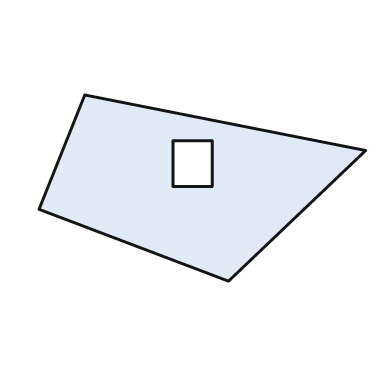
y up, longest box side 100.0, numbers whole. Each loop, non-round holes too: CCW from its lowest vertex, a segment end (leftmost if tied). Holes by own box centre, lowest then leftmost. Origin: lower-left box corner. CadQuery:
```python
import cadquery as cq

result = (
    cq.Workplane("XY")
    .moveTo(58.0, 0.0)
    .lineTo(100.0, 40.0)
    .lineTo(14.0, 57.0)
    .lineTo(0.0, 22.0)
    .close()
    .moveTo(41.0, 29.0)
    .lineTo(53.0, 29.0)
    .lineTo(53.0, 43.0)
    .lineTo(41.0, 43.0)
    .close()
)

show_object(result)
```